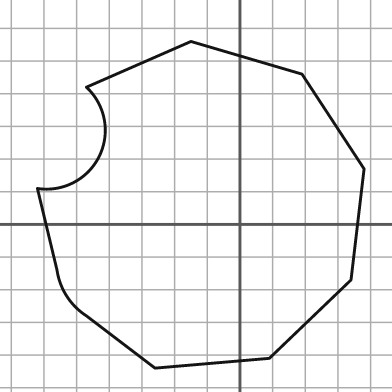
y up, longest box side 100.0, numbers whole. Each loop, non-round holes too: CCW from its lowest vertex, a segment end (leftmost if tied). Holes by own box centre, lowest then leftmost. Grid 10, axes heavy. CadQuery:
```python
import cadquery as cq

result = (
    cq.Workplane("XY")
    .moveTo(-26.0, -44.0)
    .lineTo(9.0, -41.0)
    .lineTo(34.0, -17.0)
    .lineTo(38.0, 17.0)
    .lineTo(19.0, 46.0)
    .lineTo(-15.0, 56.0)
    .lineTo(-47.0, 42.0)
    .threePointArc((-43.0, 21.0), (-62.0, 11.0))
    .lineTo(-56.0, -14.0)
    .threePointArc((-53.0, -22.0), (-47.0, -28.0))
    .close()
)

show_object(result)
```